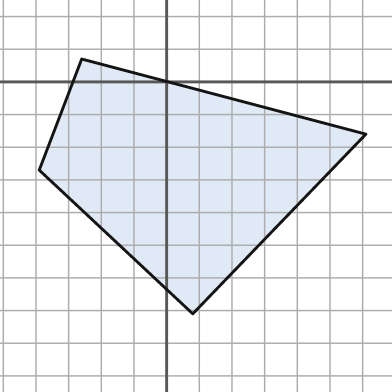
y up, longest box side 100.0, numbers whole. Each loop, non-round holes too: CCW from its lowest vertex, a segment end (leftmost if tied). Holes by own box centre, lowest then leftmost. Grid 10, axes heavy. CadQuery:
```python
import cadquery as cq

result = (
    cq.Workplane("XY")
    .moveTo(8.0, -71.0)
    .lineTo(61.0, -16.0)
    .lineTo(-26.0, 7.0)
    .lineTo(-39.0, -27.0)
    .close()
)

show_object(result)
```